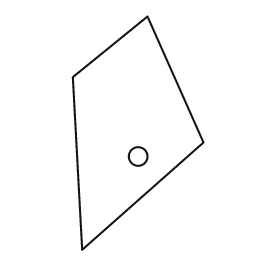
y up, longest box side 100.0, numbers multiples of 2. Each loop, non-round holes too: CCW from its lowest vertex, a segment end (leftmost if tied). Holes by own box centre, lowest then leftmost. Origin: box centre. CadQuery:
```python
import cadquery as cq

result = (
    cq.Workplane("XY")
    .moveTo(-24.0, -50.0)
    .lineTo(28.0, -4.0)
    .lineTo(4.0, 50.0)
    .lineTo(-28.0, 24.0)
    .close()
    .moveTo(0.0, -10.0)
    .circle(4.0)
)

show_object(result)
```